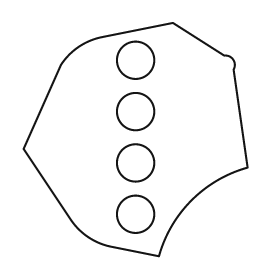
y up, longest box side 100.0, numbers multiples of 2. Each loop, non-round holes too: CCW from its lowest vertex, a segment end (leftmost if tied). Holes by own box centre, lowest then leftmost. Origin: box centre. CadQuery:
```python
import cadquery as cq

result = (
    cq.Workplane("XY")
    .moveTo(10.0, -50.0)
    .threePointArc((24.0, -26.0), (48.0, -12.0))
    .lineTo(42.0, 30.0)
    .threePointArc((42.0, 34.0), (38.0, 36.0))
    .lineTo(16.0, 50.0)
    .lineTo(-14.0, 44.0)
    .threePointArc((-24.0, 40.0), (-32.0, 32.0))
    .lineTo(-48.0, -4.0)
    .lineTo(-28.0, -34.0)
    .threePointArc((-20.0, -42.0), (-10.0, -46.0))
    .close()
    .moveTo(0.0, -32.0)
    .circle(8.0)
    .moveTo(0.0, -10.0)
    .circle(8.0)
    .moveTo(0.0, 12.0)
    .circle(8.0)
    .moveTo(0.0, 34.0)
    .circle(8.0)
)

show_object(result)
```